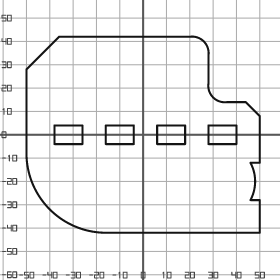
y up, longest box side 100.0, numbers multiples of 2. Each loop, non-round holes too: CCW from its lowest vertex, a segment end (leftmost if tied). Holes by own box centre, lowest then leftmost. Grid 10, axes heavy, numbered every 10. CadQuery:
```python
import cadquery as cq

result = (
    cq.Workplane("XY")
    .moveTo(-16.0, -42.0)
    .lineTo(50.0, -42.0)
    .lineTo(50.0, -28.0)
    .lineTo(46.0, -28.0)
    .threePointArc((48.0, -20.0), (46.0, -12.0))
    .lineTo(50.0, -12.0)
    .lineTo(50.0, 8.0)
    .lineTo(44.0, 14.0)
    .lineTo(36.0, 14.0)
    .threePointArc((30.0, 16.0), (28.0, 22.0))
    .lineTo(28.0, 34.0)
    .threePointArc((26.0, 40.0), (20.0, 42.0))
    .lineTo(-36.0, 42.0)
    .lineTo(-50.0, 28.0)
    .lineTo(-50.0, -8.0)
    .threePointArc((-40.0, -32.0), (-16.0, -42.0))
    .close()
    .moveTo(-38.0, -4.0)
    .lineTo(-26.0, -4.0)
    .lineTo(-26.0, 4.0)
    .lineTo(-38.0, 4.0)
    .close()
    .moveTo(-16.0, -4.0)
    .lineTo(-4.0, -4.0)
    .lineTo(-4.0, 4.0)
    .lineTo(-16.0, 4.0)
    .close()
    .moveTo(6.0, -4.0)
    .lineTo(18.0, -4.0)
    .lineTo(18.0, 4.0)
    .lineTo(6.0, 4.0)
    .close()
    .moveTo(28.0, -4.0)
    .lineTo(40.0, -4.0)
    .lineTo(40.0, 4.0)
    .lineTo(28.0, 4.0)
    .close()
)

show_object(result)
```